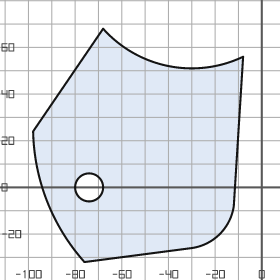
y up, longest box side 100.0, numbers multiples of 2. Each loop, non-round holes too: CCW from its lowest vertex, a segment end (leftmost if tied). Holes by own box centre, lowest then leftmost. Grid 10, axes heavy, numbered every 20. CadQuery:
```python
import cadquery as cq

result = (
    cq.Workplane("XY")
    .moveTo(-76.0, -32.0)
    .lineTo(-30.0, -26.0)
    .threePointArc((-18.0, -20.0), (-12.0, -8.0))
    .lineTo(-8.0, 56.0)
    .threePointArc((-40.0, 52.0), (-68.0, 68.0))
    .lineTo(-98.0, 24.0)
    .threePointArc((-92.0, -6.0), (-76.0, -32.0))
    .close()
    .moveTo(-74.0, 0.0)
    .circle(6.0)
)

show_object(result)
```